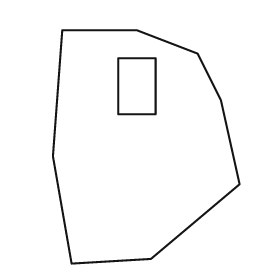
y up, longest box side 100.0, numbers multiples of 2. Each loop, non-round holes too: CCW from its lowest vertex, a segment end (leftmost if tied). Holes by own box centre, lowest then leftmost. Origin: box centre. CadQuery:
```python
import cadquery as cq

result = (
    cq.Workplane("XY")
    .moveTo(-32.0, -50.0)
    .lineTo(2.0, -48.0)
    .lineTo(40.0, -16.0)
    .lineTo(32.0, 20.0)
    .lineTo(22.0, 40.0)
    .lineTo(-4.0, 50.0)
    .lineTo(-36.0, 50.0)
    .lineTo(-40.0, -4.0)
    .close()
    .moveTo(-12.0, 14.0)
    .lineTo(4.0, 14.0)
    .lineTo(4.0, 38.0)
    .lineTo(-12.0, 38.0)
    .close()
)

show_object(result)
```